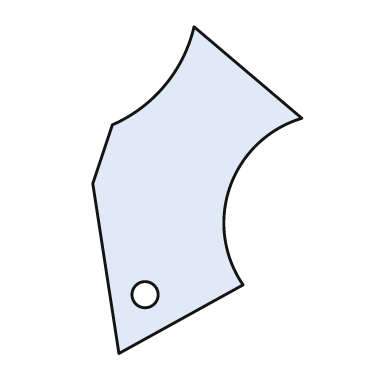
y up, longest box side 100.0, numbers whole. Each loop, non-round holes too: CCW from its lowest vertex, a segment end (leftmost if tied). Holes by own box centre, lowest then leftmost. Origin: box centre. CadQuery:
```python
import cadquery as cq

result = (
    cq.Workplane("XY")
    .moveTo(-24.0, -50.0)
    .lineTo(14.0, -29.0)
    .threePointArc((10.0, 1.0), (32.0, 22.0))
    .lineTo(-1.0, 50.0)
    .threePointArc((-10.0, 32.0), (-26.0, 20.0))
    .lineTo(-32.0, 2.0)
    .close()
    .moveTo(-16.0, -32.0)
    .circle(4.0)
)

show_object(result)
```